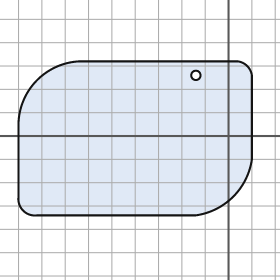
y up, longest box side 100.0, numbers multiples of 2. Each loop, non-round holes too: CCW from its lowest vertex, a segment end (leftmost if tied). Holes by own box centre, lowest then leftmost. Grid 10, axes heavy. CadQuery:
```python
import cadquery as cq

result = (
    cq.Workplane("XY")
    .moveTo(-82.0, -34.0)
    .lineTo(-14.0, -34.0)
    .threePointArc((2.0, -26.0), (10.0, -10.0))
    .lineTo(10.0, 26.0)
    .threePointArc((8.0, 30.0), (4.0, 32.0))
    .lineTo(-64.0, 32.0)
    .threePointArc((-82.0, 24.0), (-90.0, 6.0))
    .lineTo(-90.0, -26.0)
    .threePointArc((-88.0, -32.0), (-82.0, -34.0))
    .close()
    .moveTo(-14.0, 26.0)
    .circle(2.0)
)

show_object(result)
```